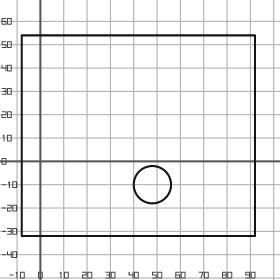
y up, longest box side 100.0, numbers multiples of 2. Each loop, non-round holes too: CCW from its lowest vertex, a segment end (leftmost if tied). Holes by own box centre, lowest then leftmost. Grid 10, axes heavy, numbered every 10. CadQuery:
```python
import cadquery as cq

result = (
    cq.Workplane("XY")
    .moveTo(-8.0, -32.0)
    .lineTo(92.0, -32.0)
    .lineTo(92.0, 54.0)
    .lineTo(-8.0, 54.0)
    .close()
    .moveTo(48.0, -10.0)
    .circle(8.0)
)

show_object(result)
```